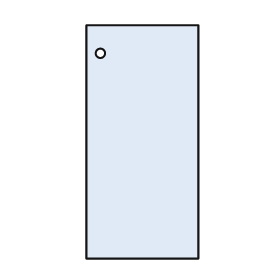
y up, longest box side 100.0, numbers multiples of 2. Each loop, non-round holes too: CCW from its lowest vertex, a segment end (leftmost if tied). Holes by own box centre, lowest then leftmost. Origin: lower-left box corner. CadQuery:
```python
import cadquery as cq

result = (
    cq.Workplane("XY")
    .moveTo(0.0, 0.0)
    .lineTo(48.0, 0.0)
    .lineTo(48.0, 100.0)
    .lineTo(0.0, 100.0)
    .close()
    .moveTo(6.0, 88.0)
    .circle(2.0)
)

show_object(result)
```